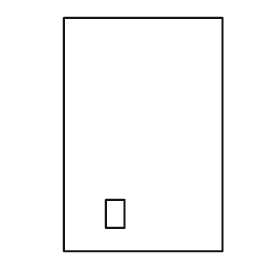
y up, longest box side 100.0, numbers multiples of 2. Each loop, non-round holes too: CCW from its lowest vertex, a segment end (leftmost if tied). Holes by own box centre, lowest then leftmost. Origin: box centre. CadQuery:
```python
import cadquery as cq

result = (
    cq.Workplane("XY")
    .moveTo(-34.0, -50.0)
    .lineTo(34.0, -50.0)
    .lineTo(34.0, 50.0)
    .lineTo(-34.0, 50.0)
    .close()
    .moveTo(-16.0, -40.0)
    .lineTo(-8.0, -40.0)
    .lineTo(-8.0, -28.0)
    .lineTo(-16.0, -28.0)
    .close()
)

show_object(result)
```